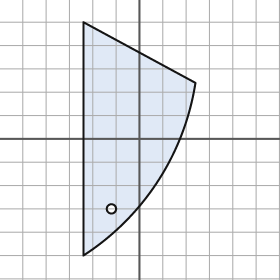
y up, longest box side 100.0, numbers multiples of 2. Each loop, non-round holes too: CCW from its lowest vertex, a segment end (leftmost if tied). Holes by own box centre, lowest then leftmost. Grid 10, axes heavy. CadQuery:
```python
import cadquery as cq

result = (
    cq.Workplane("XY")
    .moveTo(-24.0, -50.0)
    .threePointArc((8.0, -18.0), (24.0, 24.0))
    .lineTo(-24.0, 50.0)
    .close()
    .moveTo(-12.0, -30.0)
    .circle(2.0)
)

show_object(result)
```